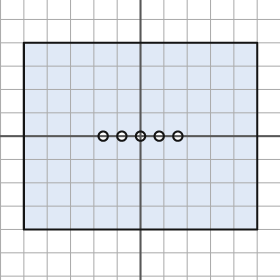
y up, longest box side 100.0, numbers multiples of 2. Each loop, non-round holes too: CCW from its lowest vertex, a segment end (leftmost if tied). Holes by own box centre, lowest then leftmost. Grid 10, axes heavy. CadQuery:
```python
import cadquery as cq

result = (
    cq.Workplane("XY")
    .moveTo(-50.0, -40.0)
    .lineTo(50.0, -40.0)
    .lineTo(50.0, 40.0)
    .lineTo(-50.0, 40.0)
    .close()
    .moveTo(-16.0, 0.0)
    .circle(2.0)
    .moveTo(-8.0, 0.0)
    .circle(2.0)
    .moveTo(0.0, 0.0)
    .circle(2.0)
    .moveTo(8.0, 0.0)
    .circle(2.0)
    .moveTo(16.0, 0.0)
    .circle(2.0)
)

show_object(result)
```